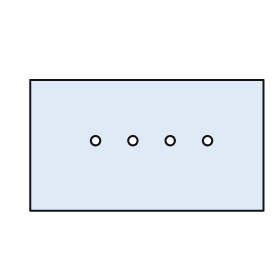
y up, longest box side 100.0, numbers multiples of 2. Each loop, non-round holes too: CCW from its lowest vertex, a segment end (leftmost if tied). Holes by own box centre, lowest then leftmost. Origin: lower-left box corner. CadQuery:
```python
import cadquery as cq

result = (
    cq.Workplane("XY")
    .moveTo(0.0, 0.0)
    .lineTo(100.0, 0.0)
    .lineTo(100.0, 56.0)
    .lineTo(0.0, 56.0)
    .close()
    .moveTo(28.0, 30.0)
    .circle(2.0)
    .moveTo(44.0, 30.0)
    .circle(2.0)
    .moveTo(60.0, 30.0)
    .circle(2.0)
    .moveTo(76.0, 30.0)
    .circle(2.0)
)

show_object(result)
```